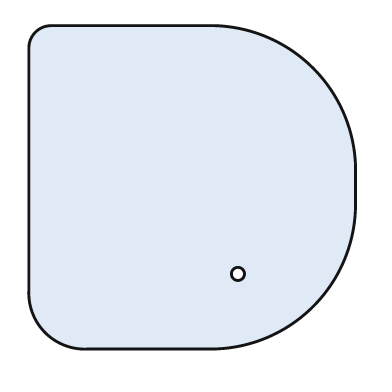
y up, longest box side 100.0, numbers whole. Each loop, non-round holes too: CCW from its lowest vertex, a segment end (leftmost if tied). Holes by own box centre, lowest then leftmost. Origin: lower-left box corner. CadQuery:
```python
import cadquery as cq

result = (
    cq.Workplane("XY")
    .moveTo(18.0, 0.0)
    .lineTo(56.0, 0.0)
    .threePointArc((87.0, 13.0), (100.0, 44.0))
    .lineTo(100.0, 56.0)
    .threePointArc((87.0, 86.0), (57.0, 99.0))
    .lineTo(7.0, 99.0)
    .threePointArc((2.0, 97.0), (0.0, 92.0))
    .lineTo(0.0, 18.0)
    .threePointArc((5.0, 5.0), (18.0, 0.0))
    .close()
    .moveTo(64.0, 23.0)
    .circle(2.0)
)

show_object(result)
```